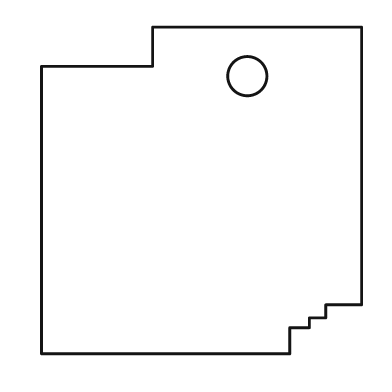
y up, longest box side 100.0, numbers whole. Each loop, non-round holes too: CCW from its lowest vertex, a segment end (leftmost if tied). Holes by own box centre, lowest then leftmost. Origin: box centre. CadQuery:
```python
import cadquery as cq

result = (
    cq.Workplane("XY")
    .moveTo(-49.0, -50.0)
    .lineTo(27.0, -50.0)
    .lineTo(27.0, -42.0)
    .lineTo(33.0, -42.0)
    .lineTo(33.0, -39.0)
    .lineTo(38.0, -39.0)
    .lineTo(38.0, -35.0)
    .lineTo(49.0, -35.0)
    .lineTo(49.0, 50.0)
    .lineTo(-15.0, 50.0)
    .lineTo(-15.0, 38.0)
    .lineTo(-49.0, 38.0)
    .close()
    .moveTo(14.0, 35.0)
    .circle(6.0)
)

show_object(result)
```